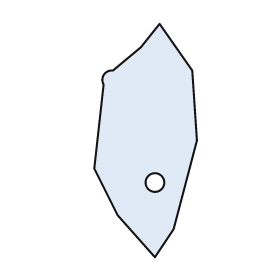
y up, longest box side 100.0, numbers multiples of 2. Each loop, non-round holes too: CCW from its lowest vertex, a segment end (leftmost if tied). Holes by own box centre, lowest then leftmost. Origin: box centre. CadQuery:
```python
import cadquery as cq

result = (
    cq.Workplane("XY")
    .moveTo(4.0, -50.0)
    .lineTo(12.0, -38.0)
    .lineTo(22.0, 0.0)
    .lineTo(20.0, 30.0)
    .lineTo(6.0, 50.0)
    .lineTo(-2.0, 40.0)
    .lineTo(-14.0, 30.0)
    .threePointArc((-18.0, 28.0), (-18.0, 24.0))
    .lineTo(-22.0, -12.0)
    .lineTo(-12.0, -32.0)
    .close()
    .moveTo(4.0, -18.0)
    .circle(4.0)
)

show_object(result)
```